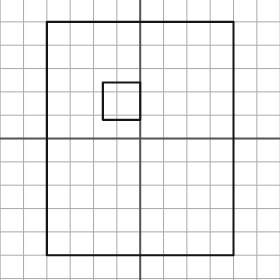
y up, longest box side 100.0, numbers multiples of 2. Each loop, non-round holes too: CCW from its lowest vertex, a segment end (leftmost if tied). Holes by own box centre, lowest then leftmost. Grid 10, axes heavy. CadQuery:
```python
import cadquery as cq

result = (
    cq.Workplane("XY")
    .moveTo(-40.0, -50.0)
    .lineTo(40.0, -50.0)
    .lineTo(40.0, 50.0)
    .lineTo(-40.0, 50.0)
    .close()
    .moveTo(-16.0, 8.0)
    .lineTo(0.0, 8.0)
    .lineTo(0.0, 24.0)
    .lineTo(-16.0, 24.0)
    .close()
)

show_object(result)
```